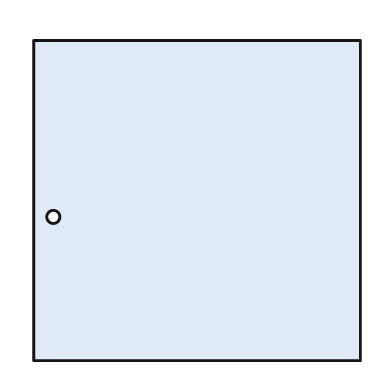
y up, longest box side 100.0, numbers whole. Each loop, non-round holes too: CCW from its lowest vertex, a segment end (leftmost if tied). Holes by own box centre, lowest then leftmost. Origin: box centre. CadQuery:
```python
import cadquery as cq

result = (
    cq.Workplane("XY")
    .moveTo(-50.0, -49.0)
    .lineTo(50.0, -49.0)
    .lineTo(50.0, 49.0)
    .lineTo(-50.0, 49.0)
    .close()
    .moveTo(-44.0, -5.0)
    .circle(2.0)
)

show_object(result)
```